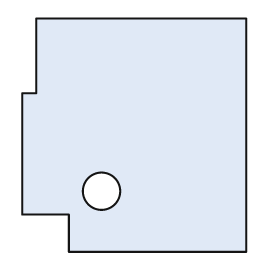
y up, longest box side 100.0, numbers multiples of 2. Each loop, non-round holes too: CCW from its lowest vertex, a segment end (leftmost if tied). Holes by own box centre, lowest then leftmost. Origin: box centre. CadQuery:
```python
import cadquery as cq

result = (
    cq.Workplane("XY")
    .moveTo(-28.0, -50.0)
    .lineTo(48.0, -50.0)
    .lineTo(48.0, 50.0)
    .lineTo(-42.0, 50.0)
    .lineTo(-42.0, 18.0)
    .lineTo(-48.0, 18.0)
    .lineTo(-48.0, -34.0)
    .lineTo(-28.0, -34.0)
    .close()
    .moveTo(-14.0, -24.0)
    .circle(8.0)
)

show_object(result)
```